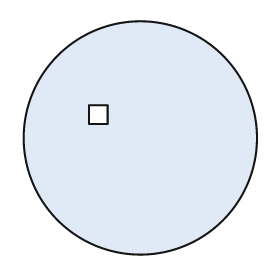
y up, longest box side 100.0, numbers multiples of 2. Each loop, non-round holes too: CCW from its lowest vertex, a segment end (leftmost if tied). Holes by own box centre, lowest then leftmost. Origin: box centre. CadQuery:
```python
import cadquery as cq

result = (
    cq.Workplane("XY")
    .moveTo(0.0, 0.0)
    .circle(50.0)
    .moveTo(-22.0, 6.0)
    .lineTo(-14.0, 6.0)
    .lineTo(-14.0, 14.0)
    .lineTo(-22.0, 14.0)
    .close()
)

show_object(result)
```